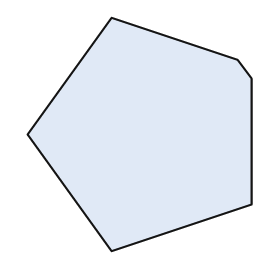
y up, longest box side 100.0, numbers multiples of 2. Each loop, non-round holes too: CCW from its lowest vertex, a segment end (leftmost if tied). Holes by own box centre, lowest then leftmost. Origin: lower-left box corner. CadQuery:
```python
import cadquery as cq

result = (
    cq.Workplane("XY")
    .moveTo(36.0, 0.0)
    .lineTo(96.0, 20.0)
    .lineTo(96.0, 74.0)
    .lineTo(90.0, 82.0)
    .lineTo(36.0, 100.0)
    .lineTo(0.0, 50.0)
    .close()
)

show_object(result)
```